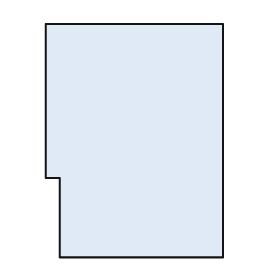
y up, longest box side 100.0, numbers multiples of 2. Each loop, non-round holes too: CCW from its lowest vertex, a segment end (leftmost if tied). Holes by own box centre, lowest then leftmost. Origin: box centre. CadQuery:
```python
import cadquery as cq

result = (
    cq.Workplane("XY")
    .moveTo(-32.0, -50.0)
    .lineTo(38.0, -50.0)
    .lineTo(38.0, 50.0)
    .lineTo(-38.0, 50.0)
    .lineTo(-38.0, -16.0)
    .lineTo(-32.0, -16.0)
    .close()
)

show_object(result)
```